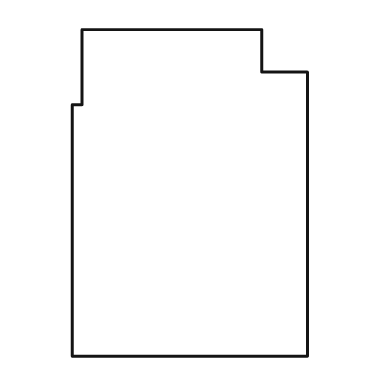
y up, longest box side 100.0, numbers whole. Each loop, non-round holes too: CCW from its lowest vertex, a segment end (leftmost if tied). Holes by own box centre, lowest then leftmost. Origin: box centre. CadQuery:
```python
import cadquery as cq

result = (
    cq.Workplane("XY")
    .moveTo(-36.0, -50.0)
    .lineTo(36.0, -50.0)
    .lineTo(36.0, 37.0)
    .lineTo(22.0, 37.0)
    .lineTo(22.0, 50.0)
    .lineTo(-33.0, 50.0)
    .lineTo(-33.0, 27.0)
    .lineTo(-36.0, 27.0)
    .close()
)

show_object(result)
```